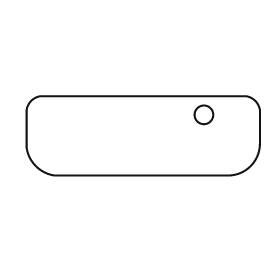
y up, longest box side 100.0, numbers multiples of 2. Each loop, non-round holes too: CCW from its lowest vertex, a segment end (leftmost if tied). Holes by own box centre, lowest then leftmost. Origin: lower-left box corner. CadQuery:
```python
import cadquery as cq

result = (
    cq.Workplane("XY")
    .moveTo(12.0, 0.0)
    .lineTo(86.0, 0.0)
    .threePointArc((96.0, 4.0), (100.0, 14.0))
    .lineTo(100.0, 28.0)
    .threePointArc((98.0, 32.0), (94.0, 34.0))
    .lineTo(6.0, 34.0)
    .threePointArc((2.0, 32.0), (0.0, 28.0))
    .lineTo(0.0, 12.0)
    .threePointArc((4.0, 4.0), (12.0, 0.0))
    .close()
    .moveTo(76.0, 26.0)
    .circle(4.0)
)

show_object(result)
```